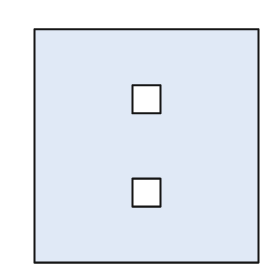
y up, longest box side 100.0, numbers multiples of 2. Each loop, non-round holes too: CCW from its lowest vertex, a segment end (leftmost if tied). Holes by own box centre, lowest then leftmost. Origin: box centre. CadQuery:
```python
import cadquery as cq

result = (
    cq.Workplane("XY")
    .moveTo(-48.0, -50.0)
    .lineTo(48.0, -50.0)
    .lineTo(48.0, 50.0)
    .lineTo(-48.0, 50.0)
    .close()
    .moveTo(-6.0, -26.0)
    .lineTo(6.0, -26.0)
    .lineTo(6.0, -14.0)
    .lineTo(-6.0, -14.0)
    .close()
    .moveTo(-6.0, 14.0)
    .lineTo(6.0, 14.0)
    .lineTo(6.0, 26.0)
    .lineTo(-6.0, 26.0)
    .close()
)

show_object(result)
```